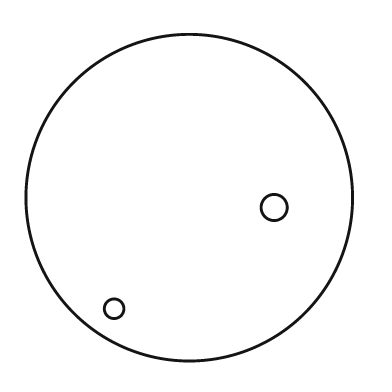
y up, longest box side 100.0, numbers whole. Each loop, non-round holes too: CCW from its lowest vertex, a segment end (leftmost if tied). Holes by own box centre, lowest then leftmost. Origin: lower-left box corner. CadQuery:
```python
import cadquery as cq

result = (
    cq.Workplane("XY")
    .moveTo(50.0, 50.0)
    .circle(50.0)
    .moveTo(27.0, 16.0)
    .circle(3.0)
    .moveTo(76.0, 47.0)
    .circle(4.0)
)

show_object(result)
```